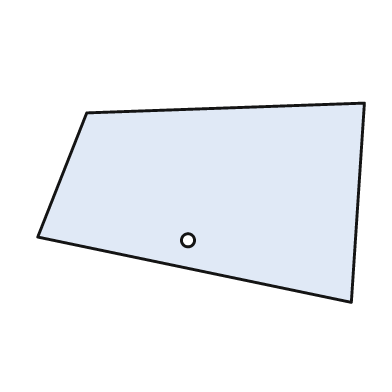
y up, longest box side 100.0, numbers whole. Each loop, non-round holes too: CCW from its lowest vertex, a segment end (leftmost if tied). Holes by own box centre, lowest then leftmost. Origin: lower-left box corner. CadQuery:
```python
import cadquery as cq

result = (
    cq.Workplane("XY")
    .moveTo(96.0, 0.0)
    .lineTo(100.0, 61.0)
    .lineTo(15.0, 58.0)
    .lineTo(0.0, 20.0)
    .close()
    .moveTo(46.0, 19.0)
    .circle(2.0)
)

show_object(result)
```